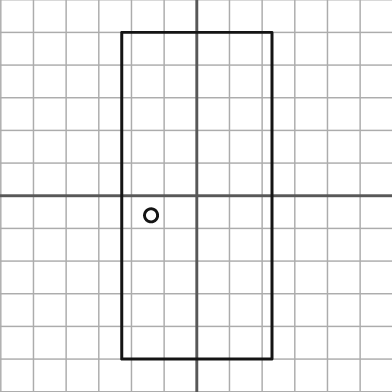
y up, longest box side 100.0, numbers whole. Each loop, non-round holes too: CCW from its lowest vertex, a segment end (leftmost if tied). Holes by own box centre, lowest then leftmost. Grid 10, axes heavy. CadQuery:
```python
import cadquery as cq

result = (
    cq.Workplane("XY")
    .moveTo(-23.0, -50.0)
    .lineTo(23.0, -50.0)
    .lineTo(23.0, 50.0)
    .lineTo(-23.0, 50.0)
    .close()
    .moveTo(-14.0, -6.0)
    .circle(2.0)
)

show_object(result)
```